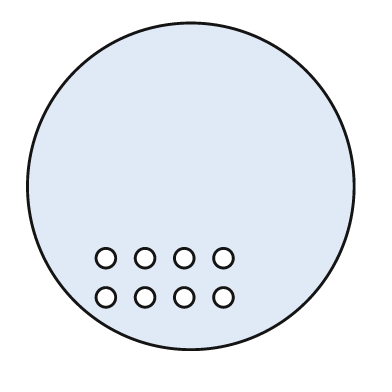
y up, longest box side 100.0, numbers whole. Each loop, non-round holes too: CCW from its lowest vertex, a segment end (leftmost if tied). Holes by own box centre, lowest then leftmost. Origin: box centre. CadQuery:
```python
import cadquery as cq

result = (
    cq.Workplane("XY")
    .moveTo(0.0, 0.0)
    .circle(50.0)
    .moveTo(-26.0, -34.0)
    .circle(3.0)
    .moveTo(-14.0, -34.0)
    .circle(3.0)
    .moveTo(-2.0, -34.0)
    .circle(3.0)
    .moveTo(10.0, -34.0)
    .circle(3.0)
    .moveTo(-26.0, -22.0)
    .circle(3.0)
    .moveTo(-14.0, -22.0)
    .circle(3.0)
    .moveTo(-2.0, -22.0)
    .circle(3.0)
    .moveTo(10.0, -22.0)
    .circle(3.0)
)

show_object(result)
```